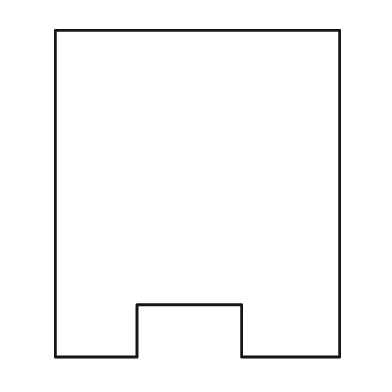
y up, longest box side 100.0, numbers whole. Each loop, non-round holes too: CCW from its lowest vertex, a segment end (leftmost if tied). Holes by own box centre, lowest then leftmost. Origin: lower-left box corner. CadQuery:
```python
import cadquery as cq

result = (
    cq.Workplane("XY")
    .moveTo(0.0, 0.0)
    .lineTo(25.0, 0.0)
    .lineTo(25.0, 16.0)
    .lineTo(57.0, 16.0)
    .lineTo(57.0, 0.0)
    .lineTo(87.0, 0.0)
    .lineTo(87.0, 100.0)
    .lineTo(0.0, 100.0)
    .close()
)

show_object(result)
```